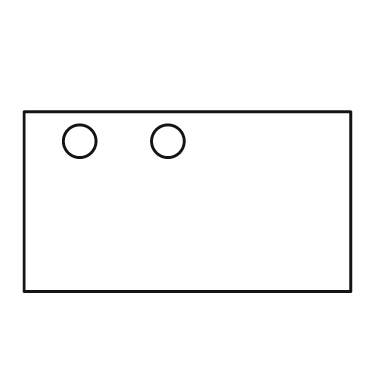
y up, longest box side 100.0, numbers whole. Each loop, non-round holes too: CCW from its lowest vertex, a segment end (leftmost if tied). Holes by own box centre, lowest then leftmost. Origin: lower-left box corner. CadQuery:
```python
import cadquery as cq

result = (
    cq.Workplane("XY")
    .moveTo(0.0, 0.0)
    .lineTo(100.0, 0.0)
    .lineTo(100.0, 55.0)
    .lineTo(0.0, 55.0)
    .close()
    .moveTo(17.0, 46.0)
    .circle(5.0)
    .moveTo(44.0, 46.0)
    .circle(5.0)
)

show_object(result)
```